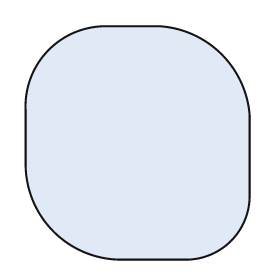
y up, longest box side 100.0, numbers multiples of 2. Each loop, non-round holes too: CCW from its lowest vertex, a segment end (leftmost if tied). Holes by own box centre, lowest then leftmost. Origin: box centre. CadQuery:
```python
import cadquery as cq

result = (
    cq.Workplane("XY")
    .moveTo(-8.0, -50.0)
    .lineTo(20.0, -50.0)
    .threePointArc((40.0, -42.0), (48.0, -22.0))
    .lineTo(48.0, 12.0)
    .threePointArc((36.0, 38.0), (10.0, 50.0))
    .lineTo(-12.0, 50.0)
    .threePointArc((-38.0, 40.0), (-48.0, 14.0))
    .lineTo(-48.0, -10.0)
    .threePointArc((-36.0, -38.0), (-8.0, -50.0))
    .close()
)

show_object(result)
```